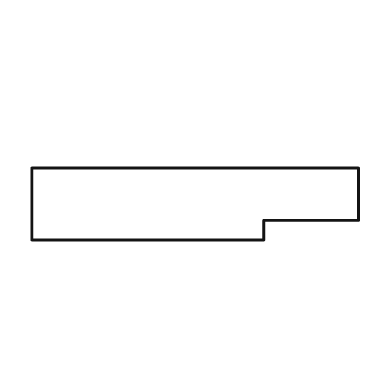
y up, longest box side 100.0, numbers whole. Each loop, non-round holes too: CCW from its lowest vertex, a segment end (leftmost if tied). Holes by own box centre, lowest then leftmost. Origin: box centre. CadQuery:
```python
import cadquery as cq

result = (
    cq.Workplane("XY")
    .moveTo(-50.0, -11.0)
    .lineTo(21.0, -11.0)
    .lineTo(21.0, -5.0)
    .lineTo(50.0, -5.0)
    .lineTo(50.0, 11.0)
    .lineTo(-50.0, 11.0)
    .close()
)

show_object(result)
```